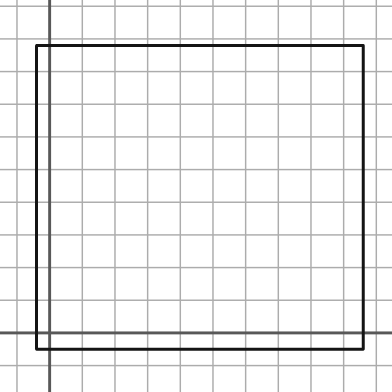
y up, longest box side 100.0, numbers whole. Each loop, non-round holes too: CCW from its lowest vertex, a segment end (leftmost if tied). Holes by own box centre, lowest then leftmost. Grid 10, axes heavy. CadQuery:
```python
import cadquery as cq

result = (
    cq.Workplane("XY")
    .moveTo(-4.0, -5.0)
    .lineTo(96.0, -5.0)
    .lineTo(96.0, 88.0)
    .lineTo(-4.0, 88.0)
    .close()
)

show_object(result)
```